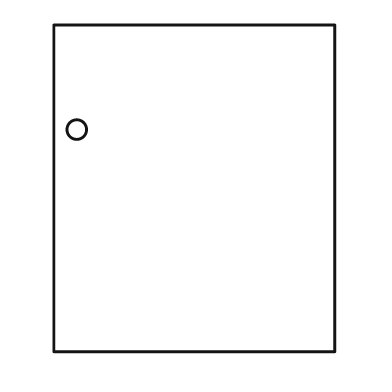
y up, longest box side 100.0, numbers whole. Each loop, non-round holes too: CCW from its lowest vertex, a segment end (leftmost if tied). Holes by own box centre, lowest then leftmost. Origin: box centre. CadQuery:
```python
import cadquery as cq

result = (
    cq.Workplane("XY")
    .moveTo(-43.0, -50.0)
    .lineTo(43.0, -50.0)
    .lineTo(43.0, 50.0)
    .lineTo(-43.0, 50.0)
    .close()
    .moveTo(-36.0, 18.0)
    .circle(3.0)
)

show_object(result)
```